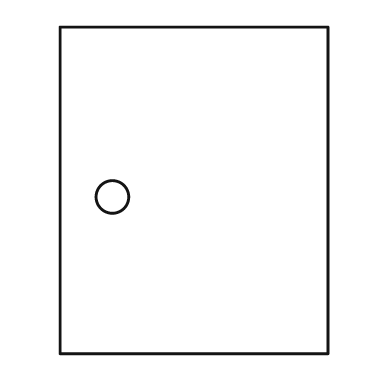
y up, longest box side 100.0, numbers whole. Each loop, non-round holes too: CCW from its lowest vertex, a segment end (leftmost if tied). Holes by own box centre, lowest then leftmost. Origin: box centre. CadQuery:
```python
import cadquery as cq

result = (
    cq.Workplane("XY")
    .moveTo(-41.0, -50.0)
    .lineTo(41.0, -50.0)
    .lineTo(41.0, 50.0)
    .lineTo(-41.0, 50.0)
    .close()
    .moveTo(-25.0, -2.0)
    .circle(5.0)
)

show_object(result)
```